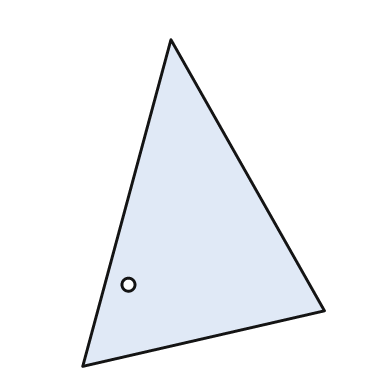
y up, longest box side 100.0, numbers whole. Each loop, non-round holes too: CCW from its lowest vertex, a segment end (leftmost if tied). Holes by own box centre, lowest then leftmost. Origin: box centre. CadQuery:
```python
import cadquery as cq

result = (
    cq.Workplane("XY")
    .moveTo(-37.0, -50.0)
    .lineTo(37.0, -33.0)
    .lineTo(-10.0, 50.0)
    .close()
    .moveTo(-23.0, -25.0)
    .circle(2.0)
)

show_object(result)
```